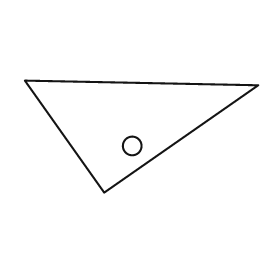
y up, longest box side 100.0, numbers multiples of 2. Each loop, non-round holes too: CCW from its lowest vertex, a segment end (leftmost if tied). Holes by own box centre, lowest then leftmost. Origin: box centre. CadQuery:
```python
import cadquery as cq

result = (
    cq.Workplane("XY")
    .moveTo(-16.0, -24.0)
    .lineTo(50.0, 22.0)
    .lineTo(-50.0, 24.0)
    .close()
    .moveTo(-4.0, -4.0)
    .circle(4.0)
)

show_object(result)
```